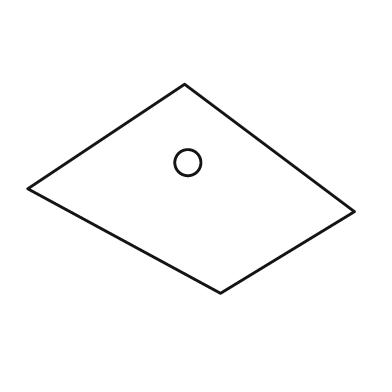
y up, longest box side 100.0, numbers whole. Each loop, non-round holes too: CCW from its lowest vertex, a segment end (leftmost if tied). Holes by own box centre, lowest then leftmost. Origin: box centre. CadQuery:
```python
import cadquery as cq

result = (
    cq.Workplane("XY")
    .moveTo(9.0, -32.0)
    .lineTo(50.0, -7.0)
    .lineTo(-2.0, 32.0)
    .lineTo(-50.0, 0.0)
    .close()
    .moveTo(-1.0, 8.0)
    .circle(4.0)
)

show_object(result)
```